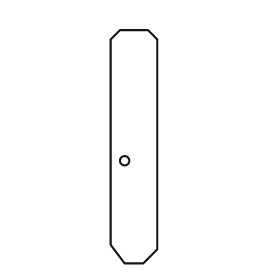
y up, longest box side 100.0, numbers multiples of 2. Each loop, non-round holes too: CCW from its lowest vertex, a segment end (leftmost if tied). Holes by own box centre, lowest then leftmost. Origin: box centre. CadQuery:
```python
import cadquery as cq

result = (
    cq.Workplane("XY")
    .moveTo(-4.0, -50.0)
    .lineTo(4.0, -50.0)
    .lineTo(10.0, -44.0)
    .lineTo(10.0, 46.0)
    .lineTo(6.0, 50.0)
    .lineTo(-6.0, 50.0)
    .lineTo(-10.0, 46.0)
    .lineTo(-10.0, -42.0)
    .close()
    .moveTo(-4.0, -6.0)
    .circle(2.0)
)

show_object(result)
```